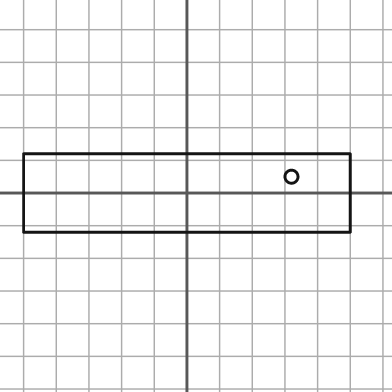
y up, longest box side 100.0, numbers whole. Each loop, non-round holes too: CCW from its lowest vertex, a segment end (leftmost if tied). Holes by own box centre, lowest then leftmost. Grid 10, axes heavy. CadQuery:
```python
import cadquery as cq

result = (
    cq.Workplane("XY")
    .moveTo(-50.0, -12.0)
    .lineTo(50.0, -12.0)
    .lineTo(50.0, 12.0)
    .lineTo(-50.0, 12.0)
    .close()
    .moveTo(32.0, 5.0)
    .circle(2.0)
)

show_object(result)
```